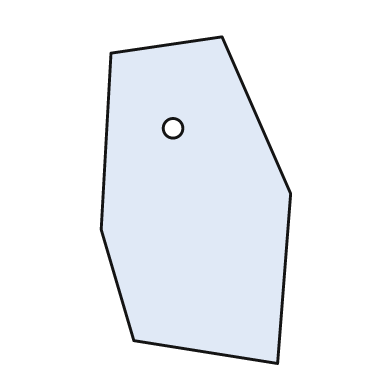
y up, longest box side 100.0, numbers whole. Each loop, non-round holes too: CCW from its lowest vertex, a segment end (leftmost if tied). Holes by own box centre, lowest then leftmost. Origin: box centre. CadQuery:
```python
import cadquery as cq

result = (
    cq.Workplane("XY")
    .moveTo(25.0, -50.0)
    .lineTo(29.0, 2.0)
    .lineTo(8.0, 50.0)
    .lineTo(-26.0, 45.0)
    .lineTo(-29.0, -9.0)
    .lineTo(-19.0, -43.0)
    .close()
    .moveTo(-7.0, 22.0)
    .circle(3.0)
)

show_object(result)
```